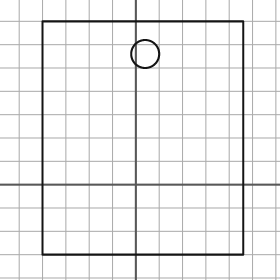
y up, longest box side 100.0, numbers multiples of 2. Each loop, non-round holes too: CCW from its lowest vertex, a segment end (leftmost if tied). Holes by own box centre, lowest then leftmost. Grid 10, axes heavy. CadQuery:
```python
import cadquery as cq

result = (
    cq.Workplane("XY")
    .moveTo(-40.0, -30.0)
    .lineTo(46.0, -30.0)
    .lineTo(46.0, 70.0)
    .lineTo(-40.0, 70.0)
    .close()
    .moveTo(4.0, 56.0)
    .circle(6.0)
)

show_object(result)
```